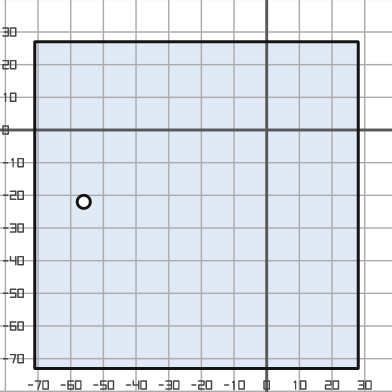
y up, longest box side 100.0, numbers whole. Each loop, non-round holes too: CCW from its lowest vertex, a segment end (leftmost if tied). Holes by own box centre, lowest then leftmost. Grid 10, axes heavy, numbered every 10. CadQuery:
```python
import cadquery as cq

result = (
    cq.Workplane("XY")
    .moveTo(-71.0, -73.0)
    .lineTo(28.0, -73.0)
    .lineTo(28.0, 27.0)
    .lineTo(-71.0, 27.0)
    .close()
    .moveTo(-56.0, -22.0)
    .circle(2.0)
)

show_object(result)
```